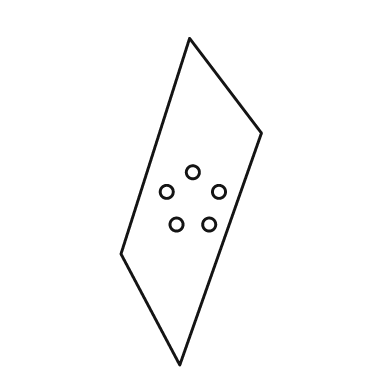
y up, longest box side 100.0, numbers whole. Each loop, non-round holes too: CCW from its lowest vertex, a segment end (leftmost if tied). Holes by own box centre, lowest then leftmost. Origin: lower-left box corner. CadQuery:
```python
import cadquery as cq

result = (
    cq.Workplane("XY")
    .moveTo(18.0, 0.0)
    .lineTo(43.0, 71.0)
    .lineTo(21.0, 100.0)
    .lineTo(0.0, 34.0)
    .close()
    .moveTo(17.0, 43.0)
    .circle(2.0)
    .moveTo(27.0, 43.0)
    .circle(2.0)
    .moveTo(14.0, 53.0)
    .circle(2.0)
    .moveTo(30.0, 53.0)
    .circle(2.0)
    .moveTo(22.0, 59.0)
    .circle(2.0)
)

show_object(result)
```